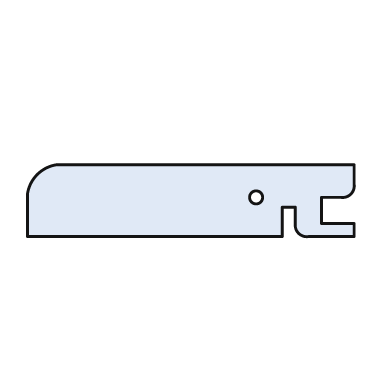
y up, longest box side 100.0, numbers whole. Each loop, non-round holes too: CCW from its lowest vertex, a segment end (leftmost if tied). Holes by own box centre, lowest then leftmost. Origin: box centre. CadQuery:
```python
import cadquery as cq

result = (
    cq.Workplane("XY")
    .moveTo(-50.0, -11.0)
    .lineTo(28.0, -11.0)
    .lineTo(28.0, -2.0)
    .lineTo(32.0, -2.0)
    .lineTo(32.0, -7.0)
    .threePointArc((33.0, -10.0), (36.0, -11.0))
    .lineTo(50.0, -11.0)
    .lineTo(50.0, -7.0)
    .lineTo(40.0, -7.0)
    .lineTo(40.0, 1.0)
    .lineTo(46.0, 1.0)
    .threePointArc((49.0, 2.0), (50.0, 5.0))
    .lineTo(50.0, 11.0)
    .lineTo(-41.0, 11.0)
    .threePointArc((-47.0, 8.0), (-50.0, 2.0))
    .close()
    .moveTo(20.0, 1.0)
    .circle(2.0)
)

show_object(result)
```